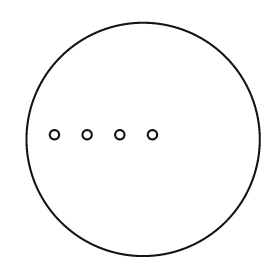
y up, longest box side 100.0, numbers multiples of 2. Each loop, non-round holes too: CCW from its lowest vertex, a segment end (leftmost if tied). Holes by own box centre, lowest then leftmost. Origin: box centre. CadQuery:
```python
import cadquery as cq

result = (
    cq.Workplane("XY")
    .moveTo(0.0, 0.0)
    .circle(50.0)
    .moveTo(-38.0, 2.0)
    .circle(2.0)
    .moveTo(-24.0, 2.0)
    .circle(2.0)
    .moveTo(-10.0, 2.0)
    .circle(2.0)
    .moveTo(4.0, 2.0)
    .circle(2.0)
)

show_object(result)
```